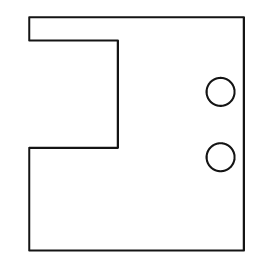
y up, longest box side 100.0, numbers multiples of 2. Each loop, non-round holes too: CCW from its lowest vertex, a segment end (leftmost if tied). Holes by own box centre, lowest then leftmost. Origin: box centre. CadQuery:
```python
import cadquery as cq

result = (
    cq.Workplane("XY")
    .moveTo(-46.0, -50.0)
    .lineTo(46.0, -50.0)
    .lineTo(46.0, 50.0)
    .lineTo(-46.0, 50.0)
    .lineTo(-46.0, 40.0)
    .lineTo(-8.0, 40.0)
    .lineTo(-8.0, -6.0)
    .lineTo(-46.0, -6.0)
    .close()
    .moveTo(36.0, -10.0)
    .circle(6.0)
    .moveTo(36.0, 18.0)
    .circle(6.0)
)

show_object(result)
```